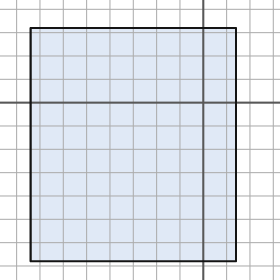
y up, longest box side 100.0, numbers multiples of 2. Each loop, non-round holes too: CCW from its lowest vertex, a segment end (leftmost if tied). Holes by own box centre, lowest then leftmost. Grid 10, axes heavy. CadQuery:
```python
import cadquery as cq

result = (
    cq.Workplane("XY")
    .moveTo(-74.0, -68.0)
    .lineTo(14.0, -68.0)
    .lineTo(14.0, 32.0)
    .lineTo(-74.0, 32.0)
    .close()
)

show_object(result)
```